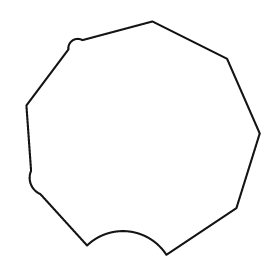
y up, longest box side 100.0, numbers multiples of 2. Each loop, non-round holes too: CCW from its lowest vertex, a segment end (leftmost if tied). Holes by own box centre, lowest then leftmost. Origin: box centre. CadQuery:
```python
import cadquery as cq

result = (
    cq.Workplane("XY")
    .moveTo(10.0, -50.0)
    .lineTo(40.0, -30.0)
    .lineTo(50.0, 2.0)
    .lineTo(36.0, 34.0)
    .lineTo(4.0, 50.0)
    .lineTo(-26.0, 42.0)
    .threePointArc((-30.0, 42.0), (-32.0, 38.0))
    .lineTo(-50.0, 14.0)
    .lineTo(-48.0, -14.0)
    .threePointArc((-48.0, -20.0), (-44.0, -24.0))
    .lineTo(-24.0, -46.0)
    .threePointArc((-6.0, -40.0), (10.0, -50.0))
    .close()
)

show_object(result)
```